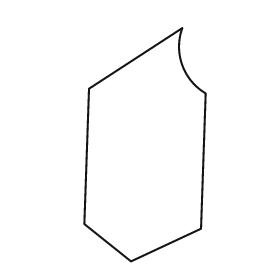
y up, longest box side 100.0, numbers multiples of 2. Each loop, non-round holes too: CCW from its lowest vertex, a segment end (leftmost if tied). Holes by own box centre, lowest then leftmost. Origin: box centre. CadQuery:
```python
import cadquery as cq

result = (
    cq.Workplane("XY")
    .moveTo(-6.0, -50.0)
    .lineTo(24.0, -36.0)
    .lineTo(26.0, 22.0)
    .threePointArc((16.0, 34.0), (16.0, 50.0))
    .lineTo(-24.0, 24.0)
    .lineTo(-26.0, -34.0)
    .close()
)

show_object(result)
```